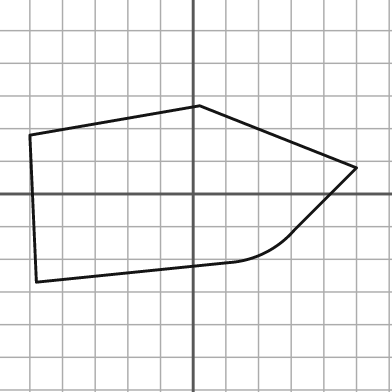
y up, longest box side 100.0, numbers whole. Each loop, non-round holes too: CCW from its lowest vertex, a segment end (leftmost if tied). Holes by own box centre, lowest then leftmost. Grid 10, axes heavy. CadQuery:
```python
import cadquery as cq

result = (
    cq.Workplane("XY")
    .moveTo(-48.0, -27.0)
    .lineTo(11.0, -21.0)
    .threePointArc((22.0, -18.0), (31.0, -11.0))
    .lineTo(50.0, 8.0)
    .lineTo(2.0, 27.0)
    .lineTo(-50.0, 18.0)
    .close()
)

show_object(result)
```